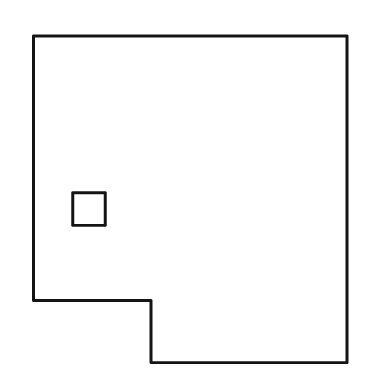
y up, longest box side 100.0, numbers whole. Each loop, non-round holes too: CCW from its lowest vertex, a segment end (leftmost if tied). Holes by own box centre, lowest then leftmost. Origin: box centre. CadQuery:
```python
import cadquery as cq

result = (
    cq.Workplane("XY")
    .moveTo(-12.0, -50.0)
    .lineTo(48.0, -50.0)
    .lineTo(48.0, 50.0)
    .lineTo(-48.0, 50.0)
    .lineTo(-48.0, -31.0)
    .lineTo(-12.0, -31.0)
    .close()
    .moveTo(-36.0, -8.0)
    .lineTo(-26.0, -8.0)
    .lineTo(-26.0, 2.0)
    .lineTo(-36.0, 2.0)
    .close()
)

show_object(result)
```